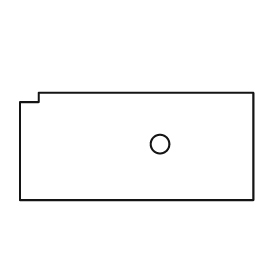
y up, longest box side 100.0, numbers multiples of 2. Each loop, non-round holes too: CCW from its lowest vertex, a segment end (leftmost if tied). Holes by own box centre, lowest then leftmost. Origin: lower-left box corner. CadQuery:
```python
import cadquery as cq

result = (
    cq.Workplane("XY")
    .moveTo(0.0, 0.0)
    .lineTo(100.0, 0.0)
    .lineTo(100.0, 46.0)
    .lineTo(8.0, 46.0)
    .lineTo(8.0, 42.0)
    .lineTo(0.0, 42.0)
    .close()
    .moveTo(60.0, 24.0)
    .circle(4.0)
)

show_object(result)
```